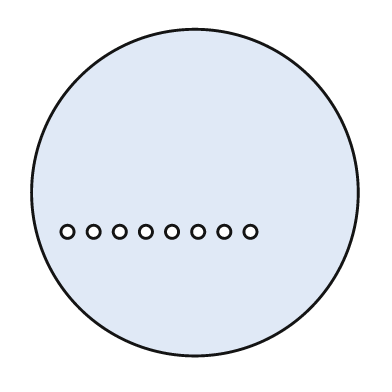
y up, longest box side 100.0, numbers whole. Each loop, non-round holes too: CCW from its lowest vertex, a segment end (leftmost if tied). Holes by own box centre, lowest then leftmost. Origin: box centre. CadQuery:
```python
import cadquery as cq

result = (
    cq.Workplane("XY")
    .moveTo(0.0, 0.0)
    .circle(50.0)
    .moveTo(-39.0, -12.0)
    .circle(2.0)
    .moveTo(-31.0, -12.0)
    .circle(2.0)
    .moveTo(-23.0, -12.0)
    .circle(2.0)
    .moveTo(-15.0, -12.0)
    .circle(2.0)
    .moveTo(-7.0, -12.0)
    .circle(2.0)
    .moveTo(1.0, -12.0)
    .circle(2.0)
    .moveTo(9.0, -12.0)
    .circle(2.0)
    .moveTo(17.0, -12.0)
    .circle(2.0)
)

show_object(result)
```